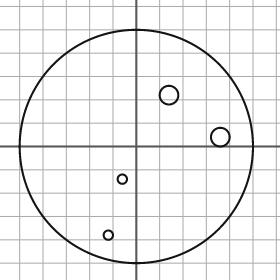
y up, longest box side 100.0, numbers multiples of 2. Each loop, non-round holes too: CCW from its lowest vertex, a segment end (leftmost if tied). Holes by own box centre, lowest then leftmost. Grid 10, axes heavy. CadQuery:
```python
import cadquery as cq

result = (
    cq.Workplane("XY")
    .moveTo(0.0, 0.0)
    .circle(50.0)
    .moveTo(-12.0, -38.0)
    .circle(2.0)
    .moveTo(-6.0, -14.0)
    .circle(2.0)
    .moveTo(36.0, 4.0)
    .circle(4.0)
    .moveTo(14.0, 22.0)
    .circle(4.0)
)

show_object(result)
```